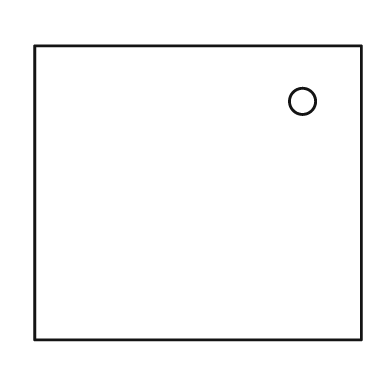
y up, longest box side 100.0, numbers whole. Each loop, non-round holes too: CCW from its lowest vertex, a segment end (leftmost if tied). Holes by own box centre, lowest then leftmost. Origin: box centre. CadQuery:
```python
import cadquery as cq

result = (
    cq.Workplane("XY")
    .moveTo(-50.0, -45.0)
    .lineTo(50.0, -45.0)
    .lineTo(50.0, 45.0)
    .lineTo(-50.0, 45.0)
    .close()
    .moveTo(32.0, 28.0)
    .circle(4.0)
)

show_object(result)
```